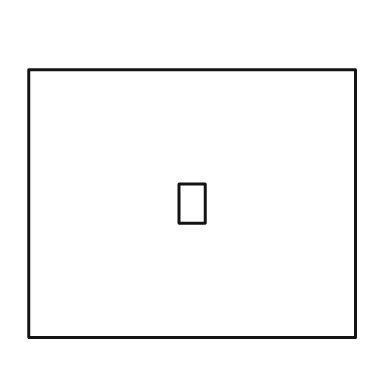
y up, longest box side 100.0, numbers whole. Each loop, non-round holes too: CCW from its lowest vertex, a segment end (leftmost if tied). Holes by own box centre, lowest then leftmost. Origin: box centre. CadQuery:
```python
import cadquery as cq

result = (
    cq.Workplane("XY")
    .moveTo(-50.0, -41.0)
    .lineTo(50.0, -41.0)
    .lineTo(50.0, 41.0)
    .lineTo(-50.0, 41.0)
    .close()
    .moveTo(-4.0, -6.0)
    .lineTo(4.0, -6.0)
    .lineTo(4.0, 6.0)
    .lineTo(-4.0, 6.0)
    .close()
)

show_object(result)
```